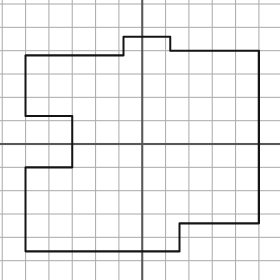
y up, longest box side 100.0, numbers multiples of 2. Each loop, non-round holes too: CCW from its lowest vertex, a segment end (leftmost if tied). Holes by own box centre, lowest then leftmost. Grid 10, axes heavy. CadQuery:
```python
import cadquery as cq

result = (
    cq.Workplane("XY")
    .moveTo(-50.0, -46.0)
    .lineTo(16.0, -46.0)
    .lineTo(16.0, -34.0)
    .lineTo(50.0, -34.0)
    .lineTo(50.0, 40.0)
    .lineTo(12.0, 40.0)
    .lineTo(12.0, 46.0)
    .lineTo(-8.0, 46.0)
    .lineTo(-8.0, 38.0)
    .lineTo(-50.0, 38.0)
    .lineTo(-50.0, 12.0)
    .lineTo(-30.0, 12.0)
    .lineTo(-30.0, -10.0)
    .lineTo(-50.0, -10.0)
    .close()
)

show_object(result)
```